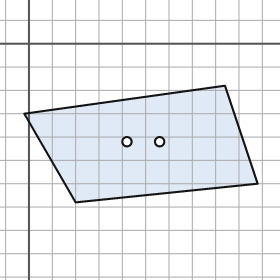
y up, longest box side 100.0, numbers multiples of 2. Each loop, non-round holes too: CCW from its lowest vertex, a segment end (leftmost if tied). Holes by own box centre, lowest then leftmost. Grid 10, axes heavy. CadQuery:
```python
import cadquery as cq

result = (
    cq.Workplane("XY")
    .moveTo(20.0, -68.0)
    .lineTo(98.0, -60.0)
    .lineTo(84.0, -18.0)
    .lineTo(-2.0, -30.0)
    .close()
    .moveTo(42.0, -42.0)
    .circle(2.0)
    .moveTo(56.0, -42.0)
    .circle(2.0)
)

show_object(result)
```